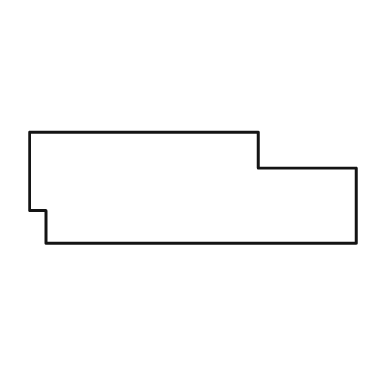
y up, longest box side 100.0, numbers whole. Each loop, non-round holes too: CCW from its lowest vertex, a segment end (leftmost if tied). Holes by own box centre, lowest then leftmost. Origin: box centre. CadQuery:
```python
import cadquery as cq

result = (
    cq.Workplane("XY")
    .moveTo(-45.0, -17.0)
    .lineTo(50.0, -17.0)
    .lineTo(50.0, 6.0)
    .lineTo(20.0, 6.0)
    .lineTo(20.0, 17.0)
    .lineTo(-50.0, 17.0)
    .lineTo(-50.0, -7.0)
    .lineTo(-45.0, -7.0)
    .close()
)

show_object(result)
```